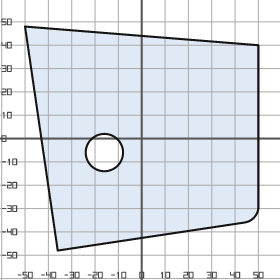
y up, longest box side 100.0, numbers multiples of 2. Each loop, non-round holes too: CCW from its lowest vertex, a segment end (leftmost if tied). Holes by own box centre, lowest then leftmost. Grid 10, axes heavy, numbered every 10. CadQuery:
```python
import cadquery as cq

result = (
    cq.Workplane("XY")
    .moveTo(-36.0, -48.0)
    .lineTo(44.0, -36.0)
    .threePointArc((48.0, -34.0), (50.0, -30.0))
    .lineTo(50.0, 40.0)
    .lineTo(-50.0, 48.0)
    .close()
    .moveTo(-16.0, -6.0)
    .circle(8.0)
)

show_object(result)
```